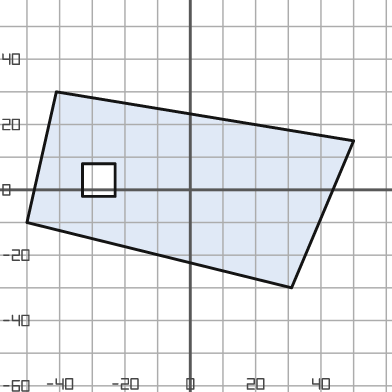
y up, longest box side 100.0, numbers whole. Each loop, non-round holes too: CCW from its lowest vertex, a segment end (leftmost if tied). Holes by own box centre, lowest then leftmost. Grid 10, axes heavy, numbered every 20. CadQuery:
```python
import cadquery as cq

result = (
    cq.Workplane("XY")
    .moveTo(31.0, -30.0)
    .lineTo(50.0, 15.0)
    .lineTo(-41.0, 30.0)
    .lineTo(-50.0, -10.0)
    .close()
    .moveTo(-33.0, -2.0)
    .lineTo(-23.0, -2.0)
    .lineTo(-23.0, 8.0)
    .lineTo(-33.0, 8.0)
    .close()
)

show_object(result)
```